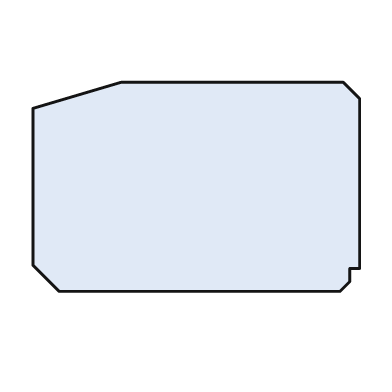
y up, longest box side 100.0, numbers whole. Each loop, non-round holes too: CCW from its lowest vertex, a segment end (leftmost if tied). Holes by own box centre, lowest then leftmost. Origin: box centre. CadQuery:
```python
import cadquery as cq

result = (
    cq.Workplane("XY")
    .moveTo(-42.0, -32.0)
    .lineTo(44.0, -32.0)
    .lineTo(47.0, -29.0)
    .lineTo(47.0, -25.0)
    .lineTo(50.0, -25.0)
    .lineTo(50.0, 27.0)
    .lineTo(45.0, 32.0)
    .lineTo(-23.0, 32.0)
    .lineTo(-50.0, 24.0)
    .lineTo(-50.0, -24.0)
    .close()
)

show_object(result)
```